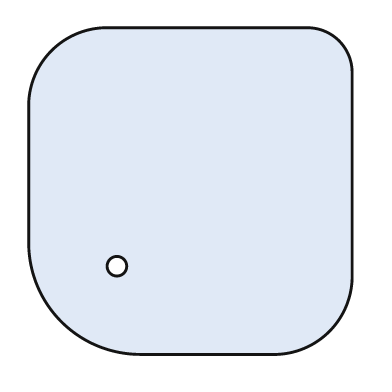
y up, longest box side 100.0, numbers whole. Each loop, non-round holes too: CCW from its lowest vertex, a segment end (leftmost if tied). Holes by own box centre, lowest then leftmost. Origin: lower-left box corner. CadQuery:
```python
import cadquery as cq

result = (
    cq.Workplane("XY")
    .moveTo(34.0, 0.0)
    .lineTo(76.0, 0.0)
    .threePointArc((92.0, 7.0), (99.0, 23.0))
    .lineTo(99.0, 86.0)
    .threePointArc((95.0, 96.0), (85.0, 100.0))
    .lineTo(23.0, 100.0)
    .threePointArc((7.0, 93.0), (0.0, 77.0))
    .lineTo(0.0, 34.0)
    .threePointArc((10.0, 10.0), (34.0, 0.0))
    .close()
    .moveTo(27.0, 27.0)
    .circle(3.0)
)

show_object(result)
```